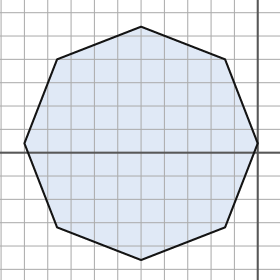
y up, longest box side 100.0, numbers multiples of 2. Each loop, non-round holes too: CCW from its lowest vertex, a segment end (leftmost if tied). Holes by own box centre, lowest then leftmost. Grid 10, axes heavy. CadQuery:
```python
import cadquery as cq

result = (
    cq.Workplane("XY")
    .moveTo(-50.0, -46.0)
    .lineTo(-14.0, -32.0)
    .lineTo(0.0, 4.0)
    .lineTo(-14.0, 40.0)
    .lineTo(-50.0, 54.0)
    .lineTo(-86.0, 40.0)
    .lineTo(-100.0, 4.0)
    .lineTo(-86.0, -32.0)
    .close()
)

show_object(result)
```